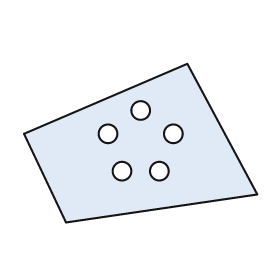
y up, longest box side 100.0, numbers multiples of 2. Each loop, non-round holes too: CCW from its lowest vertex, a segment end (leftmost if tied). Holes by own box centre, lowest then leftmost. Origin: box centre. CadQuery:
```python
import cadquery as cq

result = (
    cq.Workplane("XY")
    .moveTo(-32.0, -34.0)
    .lineTo(50.0, -22.0)
    .lineTo(20.0, 34.0)
    .lineTo(-50.0, 4.0)
    .close()
    .moveTo(-8.0, -12.0)
    .circle(4.0)
    .moveTo(8.0, -12.0)
    .circle(4.0)
    .moveTo(-14.0, 4.0)
    .circle(4.0)
    .moveTo(14.0, 4.0)
    .circle(4.0)
    .moveTo(0.0, 14.0)
    .circle(4.0)
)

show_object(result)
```